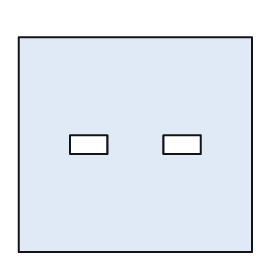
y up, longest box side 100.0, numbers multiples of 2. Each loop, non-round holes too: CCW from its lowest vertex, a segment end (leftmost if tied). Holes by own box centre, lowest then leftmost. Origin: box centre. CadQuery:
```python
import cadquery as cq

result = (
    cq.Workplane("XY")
    .moveTo(-50.0, -46.0)
    .lineTo(50.0, -46.0)
    .lineTo(50.0, 46.0)
    .lineTo(-50.0, 46.0)
    .close()
    .moveTo(-28.0, -4.0)
    .lineTo(-12.0, -4.0)
    .lineTo(-12.0, 4.0)
    .lineTo(-28.0, 4.0)
    .close()
    .moveTo(12.0, -4.0)
    .lineTo(28.0, -4.0)
    .lineTo(28.0, 4.0)
    .lineTo(12.0, 4.0)
    .close()
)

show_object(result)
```